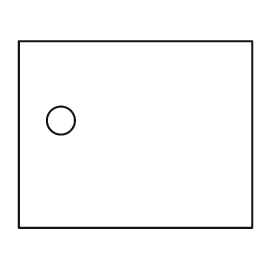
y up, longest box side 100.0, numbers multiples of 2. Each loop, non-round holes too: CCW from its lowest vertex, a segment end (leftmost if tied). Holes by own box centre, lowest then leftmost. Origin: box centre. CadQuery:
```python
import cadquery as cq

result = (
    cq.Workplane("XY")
    .moveTo(-50.0, -40.0)
    .lineTo(50.0, -40.0)
    .lineTo(50.0, 40.0)
    .lineTo(-50.0, 40.0)
    .close()
    .moveTo(-32.0, 6.0)
    .circle(6.0)
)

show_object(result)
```